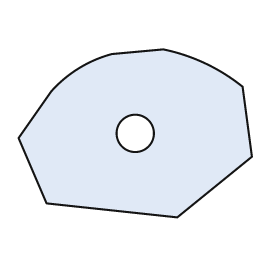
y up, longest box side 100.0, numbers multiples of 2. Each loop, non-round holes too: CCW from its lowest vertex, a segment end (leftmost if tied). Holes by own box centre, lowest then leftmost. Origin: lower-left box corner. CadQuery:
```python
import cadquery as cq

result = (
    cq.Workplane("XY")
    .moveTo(68.0, 0.0)
    .lineTo(100.0, 26.0)
    .lineTo(96.0, 56.0)
    .threePointArc((80.0, 66.0), (62.0, 72.0))
    .lineTo(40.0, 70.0)
    .threePointArc((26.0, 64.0), (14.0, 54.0))
    .lineTo(0.0, 34.0)
    .lineTo(12.0, 6.0)
    .close()
    .moveTo(50.0, 36.0)
    .circle(8.0)
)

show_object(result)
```